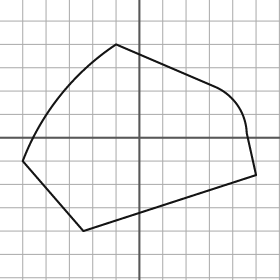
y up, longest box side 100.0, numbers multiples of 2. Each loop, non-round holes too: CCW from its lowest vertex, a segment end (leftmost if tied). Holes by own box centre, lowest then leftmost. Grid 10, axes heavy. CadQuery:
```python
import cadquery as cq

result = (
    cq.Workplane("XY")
    .moveTo(-24.0, -40.0)
    .lineTo(50.0, -16.0)
    .lineTo(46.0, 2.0)
    .threePointArc((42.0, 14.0), (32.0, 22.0))
    .lineTo(-10.0, 40.0)
    .threePointArc((-34.0, 18.0), (-50.0, -10.0))
    .close()
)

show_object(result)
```